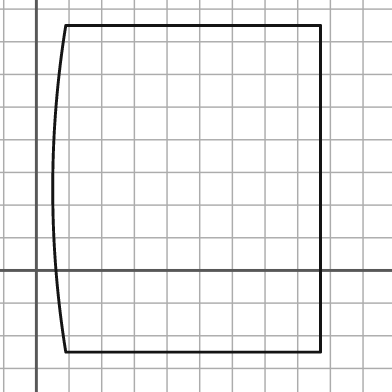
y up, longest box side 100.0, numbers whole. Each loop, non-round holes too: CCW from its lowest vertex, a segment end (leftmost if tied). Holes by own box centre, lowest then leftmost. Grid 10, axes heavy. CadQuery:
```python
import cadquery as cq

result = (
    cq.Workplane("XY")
    .moveTo(9.0, -25.0)
    .lineTo(87.0, -25.0)
    .lineTo(87.0, 75.0)
    .lineTo(9.0, 75.0)
    .threePointArc((5.0, 25.0), (9.0, -25.0))
    .close()
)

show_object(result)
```